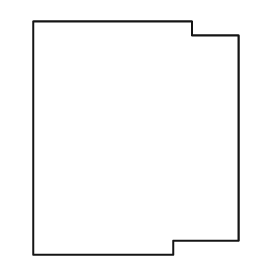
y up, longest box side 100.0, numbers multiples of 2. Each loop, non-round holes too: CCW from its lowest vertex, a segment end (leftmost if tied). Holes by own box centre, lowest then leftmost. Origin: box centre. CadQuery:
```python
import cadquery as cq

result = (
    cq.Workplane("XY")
    .moveTo(-44.0, -50.0)
    .lineTo(16.0, -50.0)
    .lineTo(16.0, -44.0)
    .lineTo(44.0, -44.0)
    .lineTo(44.0, 44.0)
    .lineTo(24.0, 44.0)
    .lineTo(24.0, 50.0)
    .lineTo(-44.0, 50.0)
    .close()
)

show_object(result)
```